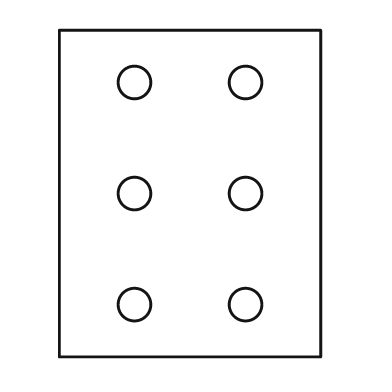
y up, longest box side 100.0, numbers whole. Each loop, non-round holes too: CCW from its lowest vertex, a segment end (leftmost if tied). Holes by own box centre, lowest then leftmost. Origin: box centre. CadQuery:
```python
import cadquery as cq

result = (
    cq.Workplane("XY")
    .moveTo(-40.0, -50.0)
    .lineTo(40.0, -50.0)
    .lineTo(40.0, 50.0)
    .lineTo(-40.0, 50.0)
    .close()
    .moveTo(-17.0, -34.0)
    .circle(5.0)
    .moveTo(17.0, -34.0)
    .circle(5.0)
    .moveTo(-17.0, 0.0)
    .circle(5.0)
    .moveTo(17.0, 0.0)
    .circle(5.0)
    .moveTo(-17.0, 34.0)
    .circle(5.0)
    .moveTo(17.0, 34.0)
    .circle(5.0)
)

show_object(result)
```